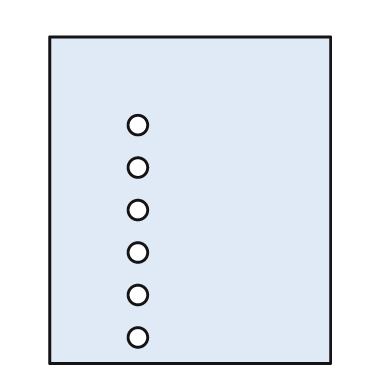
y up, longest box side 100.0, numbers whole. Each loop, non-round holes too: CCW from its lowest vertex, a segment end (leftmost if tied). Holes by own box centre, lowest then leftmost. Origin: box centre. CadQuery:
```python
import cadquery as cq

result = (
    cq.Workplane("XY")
    .moveTo(-43.0, -50.0)
    .lineTo(43.0, -50.0)
    .lineTo(43.0, 50.0)
    .lineTo(-43.0, 50.0)
    .close()
    .moveTo(-16.0, -42.0)
    .circle(3.0)
    .moveTo(-16.0, -29.0)
    .circle(3.0)
    .moveTo(-16.0, -16.0)
    .circle(3.0)
    .moveTo(-16.0, -3.0)
    .circle(3.0)
    .moveTo(-16.0, 10.0)
    .circle(3.0)
    .moveTo(-16.0, 23.0)
    .circle(3.0)
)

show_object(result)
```